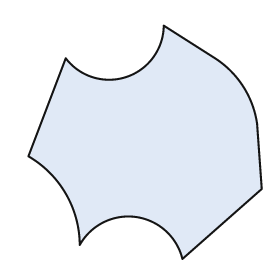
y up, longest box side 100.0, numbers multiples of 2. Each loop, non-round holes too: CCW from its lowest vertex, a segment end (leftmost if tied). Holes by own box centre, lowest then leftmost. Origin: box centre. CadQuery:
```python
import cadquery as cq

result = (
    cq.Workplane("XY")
    .moveTo(16.0, -50.0)
    .lineTo(50.0, -20.0)
    .lineTo(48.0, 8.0)
    .threePointArc((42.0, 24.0), (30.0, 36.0))
    .lineTo(8.0, 50.0)
    .threePointArc((-8.0, 28.0), (-34.0, 36.0))
    .lineTo(-50.0, -6.0)
    .threePointArc((-34.0, -22.0), (-28.0, -44.0))
    .threePointArc((-4.0, -32.0), (16.0, -50.0))
    .close()
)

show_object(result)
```